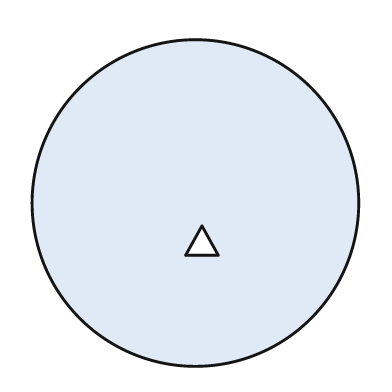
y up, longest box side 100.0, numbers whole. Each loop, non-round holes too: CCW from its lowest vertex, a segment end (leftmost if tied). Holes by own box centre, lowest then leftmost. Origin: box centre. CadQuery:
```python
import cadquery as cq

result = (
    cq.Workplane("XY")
    .moveTo(0.0, 0.0)
    .circle(50.0)
    .moveTo(-3.0, -16.0)
    .lineTo(7.0, -16.0)
    .lineTo(2.0, -7.0)
    .close()
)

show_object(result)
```